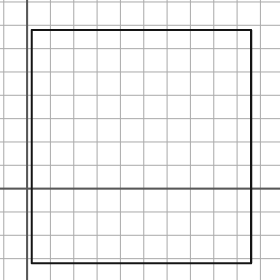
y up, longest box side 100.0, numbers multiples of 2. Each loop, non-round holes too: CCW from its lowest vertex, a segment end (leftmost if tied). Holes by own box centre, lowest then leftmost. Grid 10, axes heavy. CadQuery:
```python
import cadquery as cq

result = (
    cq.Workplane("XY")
    .moveTo(2.0, -32.0)
    .lineTo(96.0, -32.0)
    .lineTo(96.0, 68.0)
    .lineTo(2.0, 68.0)
    .close()
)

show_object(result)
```